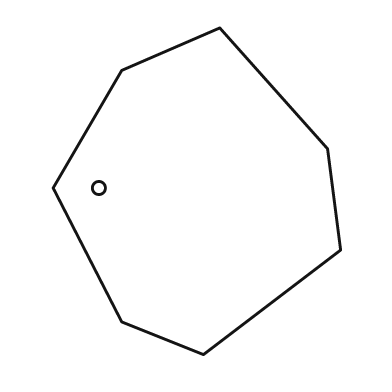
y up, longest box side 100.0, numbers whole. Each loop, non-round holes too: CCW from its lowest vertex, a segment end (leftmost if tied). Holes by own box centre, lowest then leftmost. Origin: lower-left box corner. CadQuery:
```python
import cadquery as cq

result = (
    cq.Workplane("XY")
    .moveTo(46.0, 0.0)
    .lineTo(88.0, 32.0)
    .lineTo(84.0, 63.0)
    .lineTo(51.0, 100.0)
    .lineTo(21.0, 87.0)
    .lineTo(0.0, 51.0)
    .lineTo(21.0, 10.0)
    .close()
    .moveTo(14.0, 51.0)
    .circle(2.0)
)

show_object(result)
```